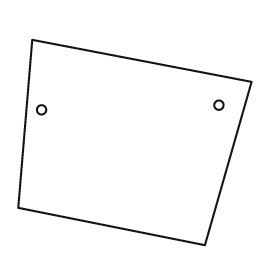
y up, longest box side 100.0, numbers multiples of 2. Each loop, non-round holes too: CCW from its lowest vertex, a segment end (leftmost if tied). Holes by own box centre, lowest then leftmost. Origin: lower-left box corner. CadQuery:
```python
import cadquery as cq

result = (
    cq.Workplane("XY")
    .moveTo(80.0, 0.0)
    .lineTo(100.0, 70.0)
    .lineTo(6.0, 88.0)
    .lineTo(0.0, 16.0)
    .close()
    .moveTo(10.0, 58.0)
    .circle(2.0)
    .moveTo(86.0, 60.0)
    .circle(2.0)
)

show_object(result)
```